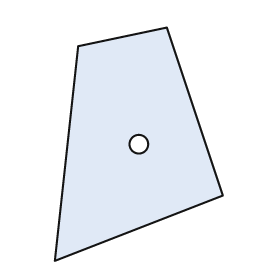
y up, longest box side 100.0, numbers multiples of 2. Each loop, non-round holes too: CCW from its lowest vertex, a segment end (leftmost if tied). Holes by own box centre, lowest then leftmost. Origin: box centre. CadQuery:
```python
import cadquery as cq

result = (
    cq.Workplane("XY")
    .moveTo(-36.0, -50.0)
    .lineTo(36.0, -22.0)
    .lineTo(12.0, 50.0)
    .lineTo(-26.0, 42.0)
    .close()
    .moveTo(0.0, 0.0)
    .circle(4.0)
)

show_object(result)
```